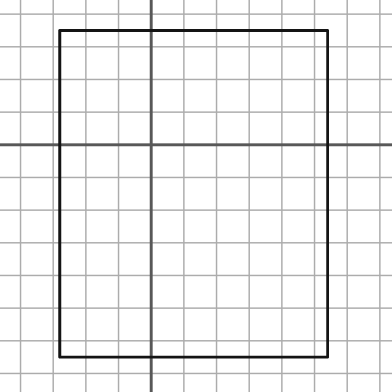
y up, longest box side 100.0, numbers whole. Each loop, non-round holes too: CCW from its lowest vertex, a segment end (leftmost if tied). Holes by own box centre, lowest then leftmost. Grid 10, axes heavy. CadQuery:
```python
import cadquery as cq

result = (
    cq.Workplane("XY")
    .moveTo(-28.0, -65.0)
    .lineTo(54.0, -65.0)
    .lineTo(54.0, 35.0)
    .lineTo(-28.0, 35.0)
    .close()
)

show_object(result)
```